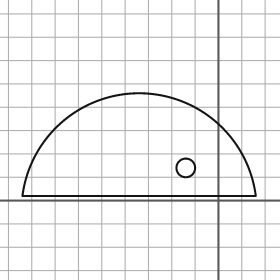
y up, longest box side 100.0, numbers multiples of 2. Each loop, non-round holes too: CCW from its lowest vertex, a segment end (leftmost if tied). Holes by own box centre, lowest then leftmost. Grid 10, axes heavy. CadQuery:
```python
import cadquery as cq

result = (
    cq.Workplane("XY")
    .moveTo(-84.0, 2.0)
    .lineTo(16.0, 2.0)
    .threePointArc((-34.0, 46.0), (-84.0, 2.0))
    .close()
    .moveTo(-14.0, 14.0)
    .circle(4.0)
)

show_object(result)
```